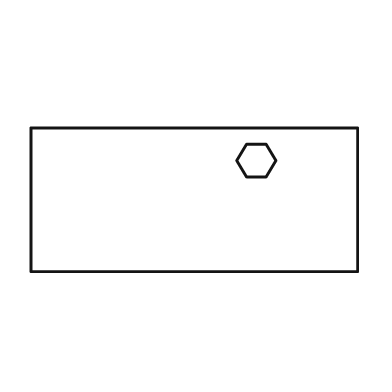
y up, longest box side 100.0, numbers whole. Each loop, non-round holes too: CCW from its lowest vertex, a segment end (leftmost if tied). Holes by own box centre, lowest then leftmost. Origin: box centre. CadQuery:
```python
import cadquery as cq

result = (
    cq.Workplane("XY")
    .moveTo(-50.0, -22.0)
    .lineTo(50.0, -22.0)
    .lineTo(50.0, 22.0)
    .lineTo(-50.0, 22.0)
    .close()
    .moveTo(16.0, 7.0)
    .lineTo(22.0, 7.0)
    .lineTo(25.0, 12.0)
    .lineTo(22.0, 17.0)
    .lineTo(16.0, 17.0)
    .lineTo(13.0, 12.0)
    .close()
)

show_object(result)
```